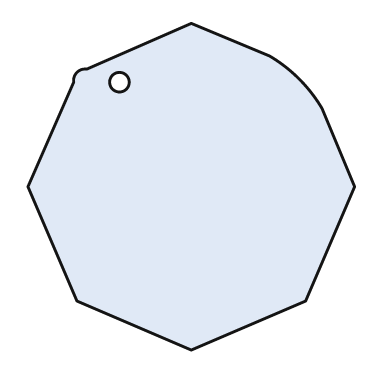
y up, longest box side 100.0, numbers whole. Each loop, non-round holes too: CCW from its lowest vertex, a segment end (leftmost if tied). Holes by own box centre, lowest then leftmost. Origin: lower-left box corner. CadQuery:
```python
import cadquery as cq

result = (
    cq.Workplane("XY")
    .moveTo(50.0, 0.0)
    .lineTo(85.0, 15.0)
    .lineTo(100.0, 50.0)
    .lineTo(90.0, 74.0)
    .threePointArc((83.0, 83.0), (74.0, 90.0))
    .lineTo(50.0, 100.0)
    .lineTo(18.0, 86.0)
    .threePointArc((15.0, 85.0), (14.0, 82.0))
    .lineTo(0.0, 50.0)
    .lineTo(15.0, 15.0)
    .close()
    .moveTo(28.0, 82.0)
    .circle(3.0)
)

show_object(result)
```